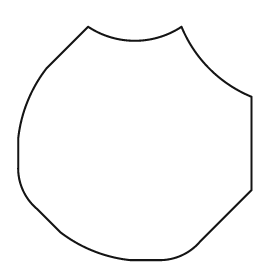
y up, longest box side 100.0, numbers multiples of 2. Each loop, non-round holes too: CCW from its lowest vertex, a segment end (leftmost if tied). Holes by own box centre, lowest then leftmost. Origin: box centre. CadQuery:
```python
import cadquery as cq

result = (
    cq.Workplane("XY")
    .moveTo(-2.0, -50.0)
    .lineTo(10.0, -50.0)
    .threePointArc((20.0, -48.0), (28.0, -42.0))
    .lineTo(50.0, -20.0)
    .lineTo(50.0, 20.0)
    .threePointArc((32.0, 32.0), (20.0, 50.0))
    .threePointArc((0.0, 44.0), (-20.0, 50.0))
    .lineTo(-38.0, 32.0)
    .threePointArc((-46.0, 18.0), (-50.0, 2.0))
    .lineTo(-50.0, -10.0)
    .threePointArc((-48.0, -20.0), (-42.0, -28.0))
    .lineTo(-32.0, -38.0)
    .threePointArc((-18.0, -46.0), (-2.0, -50.0))
    .close()
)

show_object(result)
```